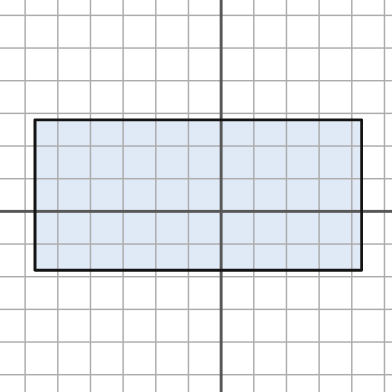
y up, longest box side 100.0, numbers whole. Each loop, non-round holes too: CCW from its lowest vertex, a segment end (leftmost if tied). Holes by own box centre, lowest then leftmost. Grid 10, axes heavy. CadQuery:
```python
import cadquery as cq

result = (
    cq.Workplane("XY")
    .moveTo(-57.0, -18.0)
    .lineTo(43.0, -18.0)
    .lineTo(43.0, 28.0)
    .lineTo(-57.0, 28.0)
    .close()
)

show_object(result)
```